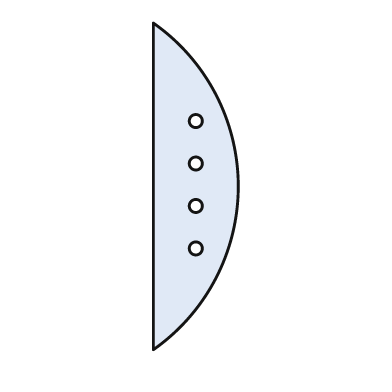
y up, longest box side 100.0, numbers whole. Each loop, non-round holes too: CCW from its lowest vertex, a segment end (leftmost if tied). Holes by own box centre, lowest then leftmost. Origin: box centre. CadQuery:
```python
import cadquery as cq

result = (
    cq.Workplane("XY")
    .moveTo(-13.0, -50.0)
    .threePointArc((13.0, 0.0), (-13.0, 50.0))
    .close()
    .moveTo(0.0, -19.0)
    .circle(2.0)
    .moveTo(0.0, -6.0)
    .circle(2.0)
    .moveTo(0.0, 7.0)
    .circle(2.0)
    .moveTo(0.0, 20.0)
    .circle(2.0)
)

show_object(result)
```